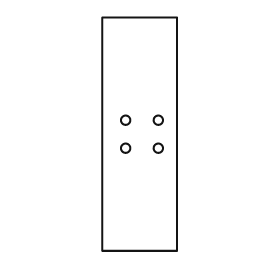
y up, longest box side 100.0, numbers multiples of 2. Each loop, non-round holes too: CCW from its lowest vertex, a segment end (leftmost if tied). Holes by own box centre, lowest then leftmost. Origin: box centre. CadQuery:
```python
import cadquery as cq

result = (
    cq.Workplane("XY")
    .moveTo(-16.0, -50.0)
    .lineTo(16.0, -50.0)
    .lineTo(16.0, 50.0)
    .lineTo(-16.0, 50.0)
    .close()
    .moveTo(-6.0, -6.0)
    .circle(2.0)
    .moveTo(8.0, -6.0)
    .circle(2.0)
    .moveTo(-6.0, 6.0)
    .circle(2.0)
    .moveTo(8.0, 6.0)
    .circle(2.0)
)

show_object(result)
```